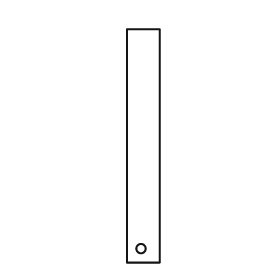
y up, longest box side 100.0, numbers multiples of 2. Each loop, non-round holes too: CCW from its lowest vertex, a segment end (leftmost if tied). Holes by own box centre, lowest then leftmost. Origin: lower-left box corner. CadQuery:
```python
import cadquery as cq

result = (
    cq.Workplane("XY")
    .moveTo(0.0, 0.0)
    .lineTo(14.0, 0.0)
    .lineTo(14.0, 100.0)
    .lineTo(0.0, 100.0)
    .close()
    .moveTo(6.0, 6.0)
    .circle(2.0)
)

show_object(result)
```